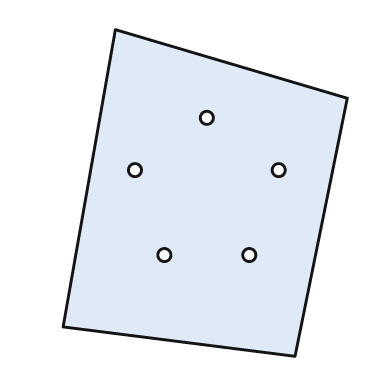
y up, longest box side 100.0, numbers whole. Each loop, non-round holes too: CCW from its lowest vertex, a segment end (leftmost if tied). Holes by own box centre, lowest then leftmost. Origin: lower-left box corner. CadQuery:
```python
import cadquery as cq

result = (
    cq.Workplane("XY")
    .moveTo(71.0, 0.0)
    .lineTo(87.0, 79.0)
    .lineTo(16.0, 100.0)
    .lineTo(0.0, 9.0)
    .close()
    .moveTo(31.0, 31.0)
    .circle(2.0)
    .moveTo(57.0, 31.0)
    .circle(2.0)
    .moveTo(22.0, 57.0)
    .circle(2.0)
    .moveTo(66.0, 57.0)
    .circle(2.0)
    .moveTo(44.0, 73.0)
    .circle(2.0)
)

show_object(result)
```